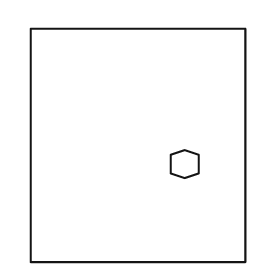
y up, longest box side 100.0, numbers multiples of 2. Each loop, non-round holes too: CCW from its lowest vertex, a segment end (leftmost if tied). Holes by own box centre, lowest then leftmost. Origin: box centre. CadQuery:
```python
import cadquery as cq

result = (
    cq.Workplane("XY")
    .moveTo(-46.0, -50.0)
    .lineTo(46.0, -50.0)
    .lineTo(46.0, 50.0)
    .lineTo(-46.0, 50.0)
    .close()
    .moveTo(20.0, -14.0)
    .lineTo(26.0, -12.0)
    .lineTo(26.0, -4.0)
    .lineTo(20.0, -2.0)
    .lineTo(14.0, -4.0)
    .lineTo(14.0, -12.0)
    .close()
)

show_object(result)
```